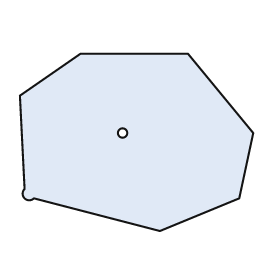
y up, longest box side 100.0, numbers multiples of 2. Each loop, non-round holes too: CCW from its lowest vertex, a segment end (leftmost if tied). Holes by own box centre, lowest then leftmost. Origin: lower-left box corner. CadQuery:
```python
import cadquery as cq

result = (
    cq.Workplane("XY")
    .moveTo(60.0, 0.0)
    .lineTo(94.0, 14.0)
    .lineTo(100.0, 42.0)
    .lineTo(72.0, 76.0)
    .lineTo(26.0, 76.0)
    .lineTo(0.0, 58.0)
    .lineTo(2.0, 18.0)
    .threePointArc((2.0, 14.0), (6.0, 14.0))
    .close()
    .moveTo(44.0, 42.0)
    .circle(2.0)
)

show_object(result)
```